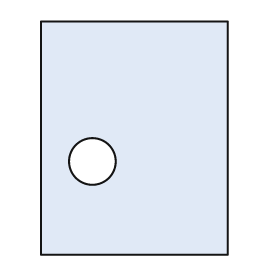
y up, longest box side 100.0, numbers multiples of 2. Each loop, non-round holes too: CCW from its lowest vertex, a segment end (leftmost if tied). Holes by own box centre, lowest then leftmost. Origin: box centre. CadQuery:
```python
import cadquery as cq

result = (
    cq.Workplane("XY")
    .moveTo(-40.0, -50.0)
    .lineTo(40.0, -50.0)
    .lineTo(40.0, 50.0)
    .lineTo(-40.0, 50.0)
    .close()
    .moveTo(-18.0, -10.0)
    .circle(10.0)
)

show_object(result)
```